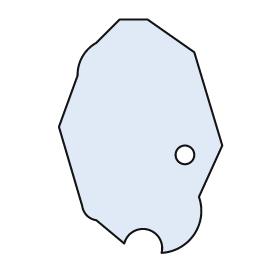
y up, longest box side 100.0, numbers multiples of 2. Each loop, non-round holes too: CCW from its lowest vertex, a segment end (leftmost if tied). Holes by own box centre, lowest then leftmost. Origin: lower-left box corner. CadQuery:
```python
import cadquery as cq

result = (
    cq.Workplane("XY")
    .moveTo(44.0, 0.0)
    .threePointArc((58.0, 8.0), (60.0, 24.0))
    .lineTo(70.0, 46.0)
    .lineTo(58.0, 86.0)
    .lineTo(38.0, 100.0)
    .lineTo(26.0, 100.0)
    .lineTo(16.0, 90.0)
    .threePointArc((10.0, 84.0), (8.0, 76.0))
    .lineTo(0.0, 54.0)
    .lineTo(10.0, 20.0)
    .threePointArc((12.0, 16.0), (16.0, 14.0))
    .lineTo(28.0, 4.0)
    .threePointArc((38.0, 10.0), (44.0, 0.0))
    .close()
    .moveTo(54.0, 42.0)
    .circle(4.0)
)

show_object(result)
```